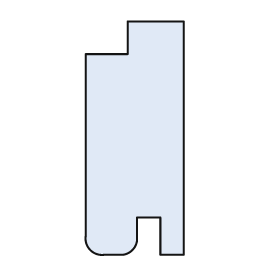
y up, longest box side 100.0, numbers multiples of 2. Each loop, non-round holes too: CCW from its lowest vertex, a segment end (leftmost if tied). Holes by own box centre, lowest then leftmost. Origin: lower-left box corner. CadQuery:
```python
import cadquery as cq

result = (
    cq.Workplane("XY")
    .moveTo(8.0, 0.0)
    .lineTo(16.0, 0.0)
    .threePointArc((20.0, 2.0), (22.0, 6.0))
    .lineTo(22.0, 16.0)
    .lineTo(32.0, 16.0)
    .lineTo(32.0, 0.0)
    .lineTo(42.0, 0.0)
    .lineTo(42.0, 100.0)
    .lineTo(18.0, 100.0)
    .lineTo(18.0, 86.0)
    .lineTo(0.0, 86.0)
    .lineTo(0.0, 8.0)
    .threePointArc((2.0, 2.0), (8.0, 0.0))
    .close()
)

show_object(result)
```